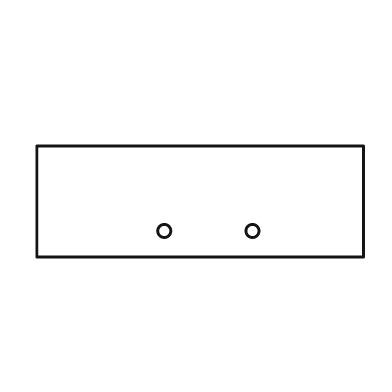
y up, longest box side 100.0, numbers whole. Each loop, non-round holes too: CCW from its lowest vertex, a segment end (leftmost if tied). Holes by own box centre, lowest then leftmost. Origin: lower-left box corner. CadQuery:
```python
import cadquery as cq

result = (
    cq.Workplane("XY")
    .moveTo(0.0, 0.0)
    .lineTo(100.0, 0.0)
    .lineTo(100.0, 34.0)
    .lineTo(0.0, 34.0)
    .close()
    .moveTo(39.0, 8.0)
    .circle(2.0)
    .moveTo(66.0, 8.0)
    .circle(2.0)
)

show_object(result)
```